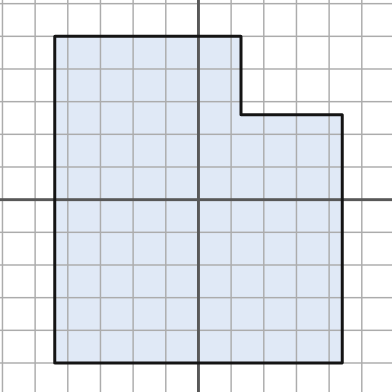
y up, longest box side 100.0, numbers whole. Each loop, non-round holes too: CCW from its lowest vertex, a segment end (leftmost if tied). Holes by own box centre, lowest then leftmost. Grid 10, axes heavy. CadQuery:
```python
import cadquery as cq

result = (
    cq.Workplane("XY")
    .moveTo(-44.0, -50.0)
    .lineTo(44.0, -50.0)
    .lineTo(44.0, 26.0)
    .lineTo(13.0, 26.0)
    .lineTo(13.0, 50.0)
    .lineTo(-44.0, 50.0)
    .close()
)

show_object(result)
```